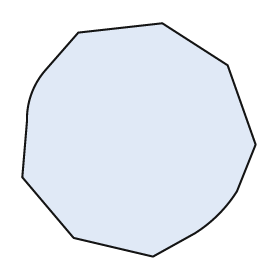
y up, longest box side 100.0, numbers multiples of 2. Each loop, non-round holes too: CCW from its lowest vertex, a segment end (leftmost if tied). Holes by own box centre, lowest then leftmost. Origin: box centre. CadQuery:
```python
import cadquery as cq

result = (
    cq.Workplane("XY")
    .moveTo(6.0, -50.0)
    .lineTo(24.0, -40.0)
    .threePointArc((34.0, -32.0), (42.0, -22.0))
    .lineTo(50.0, -2.0)
    .lineTo(38.0, 32.0)
    .lineTo(10.0, 50.0)
    .lineTo(-26.0, 46.0)
    .lineTo(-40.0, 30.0)
    .threePointArc((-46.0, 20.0), (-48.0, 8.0))
    .lineTo(-50.0, -16.0)
    .lineTo(-28.0, -42.0)
    .close()
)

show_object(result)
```